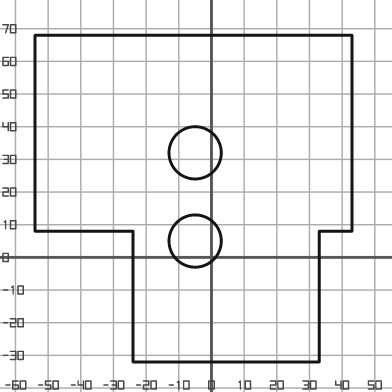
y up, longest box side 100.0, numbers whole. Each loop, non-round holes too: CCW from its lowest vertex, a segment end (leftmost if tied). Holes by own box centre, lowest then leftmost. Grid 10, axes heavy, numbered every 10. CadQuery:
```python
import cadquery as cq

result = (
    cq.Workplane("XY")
    .moveTo(-24.0, -32.0)
    .lineTo(33.0, -32.0)
    .lineTo(33.0, 8.0)
    .lineTo(43.0, 8.0)
    .lineTo(43.0, 68.0)
    .lineTo(-54.0, 68.0)
    .lineTo(-54.0, 8.0)
    .lineTo(-24.0, 8.0)
    .close()
    .moveTo(-5.0, 5.0)
    .circle(8.0)
    .moveTo(-5.0, 32.0)
    .circle(8.0)
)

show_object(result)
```